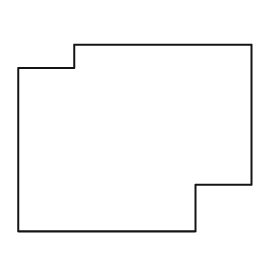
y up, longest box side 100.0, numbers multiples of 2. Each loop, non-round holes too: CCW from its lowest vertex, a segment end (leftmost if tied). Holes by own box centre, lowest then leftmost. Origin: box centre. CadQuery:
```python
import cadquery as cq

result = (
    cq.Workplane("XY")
    .moveTo(-50.0, -40.0)
    .lineTo(26.0, -40.0)
    .lineTo(26.0, -20.0)
    .lineTo(50.0, -20.0)
    .lineTo(50.0, 40.0)
    .lineTo(-26.0, 40.0)
    .lineTo(-26.0, 30.0)
    .lineTo(-50.0, 30.0)
    .close()
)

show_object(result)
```